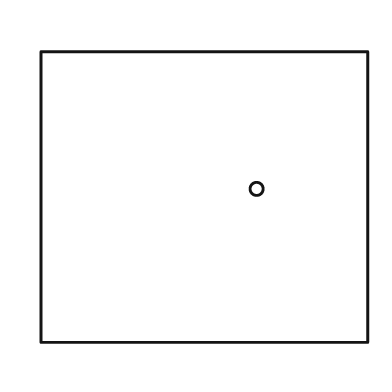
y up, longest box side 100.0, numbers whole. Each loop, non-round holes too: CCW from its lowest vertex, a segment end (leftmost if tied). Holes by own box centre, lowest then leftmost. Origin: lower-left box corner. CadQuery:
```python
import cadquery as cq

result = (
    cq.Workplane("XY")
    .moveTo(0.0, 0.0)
    .lineTo(100.0, 0.0)
    .lineTo(100.0, 89.0)
    .lineTo(0.0, 89.0)
    .close()
    .moveTo(66.0, 47.0)
    .circle(2.0)
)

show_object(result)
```